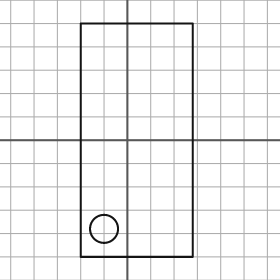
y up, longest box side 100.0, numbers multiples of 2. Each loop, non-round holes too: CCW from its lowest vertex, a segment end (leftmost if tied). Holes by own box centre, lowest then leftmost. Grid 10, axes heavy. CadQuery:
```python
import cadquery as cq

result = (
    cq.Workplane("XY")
    .moveTo(-20.0, -50.0)
    .lineTo(28.0, -50.0)
    .lineTo(28.0, 50.0)
    .lineTo(-20.0, 50.0)
    .close()
    .moveTo(-10.0, -38.0)
    .circle(6.0)
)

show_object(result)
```